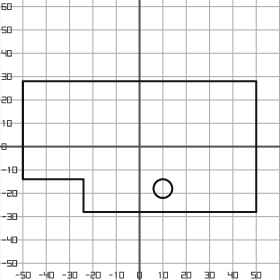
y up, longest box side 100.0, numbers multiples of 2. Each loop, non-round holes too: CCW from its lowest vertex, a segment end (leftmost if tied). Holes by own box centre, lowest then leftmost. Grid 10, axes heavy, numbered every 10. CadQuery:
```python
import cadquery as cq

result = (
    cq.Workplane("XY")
    .moveTo(-24.0, -28.0)
    .lineTo(50.0, -28.0)
    .lineTo(50.0, 28.0)
    .lineTo(-50.0, 28.0)
    .lineTo(-50.0, -14.0)
    .lineTo(-24.0, -14.0)
    .close()
    .moveTo(10.0, -18.0)
    .circle(4.0)
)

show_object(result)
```